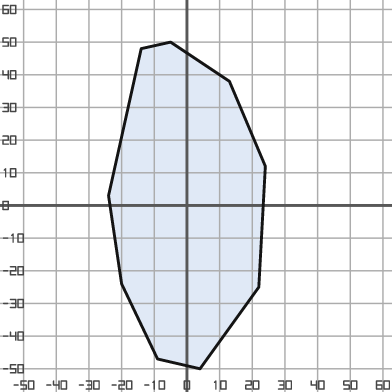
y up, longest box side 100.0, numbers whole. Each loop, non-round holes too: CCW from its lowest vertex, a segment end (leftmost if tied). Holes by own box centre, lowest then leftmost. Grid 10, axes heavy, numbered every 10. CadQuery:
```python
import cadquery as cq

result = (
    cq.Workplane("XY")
    .moveTo(4.0, -50.0)
    .lineTo(22.0, -25.0)
    .lineTo(24.0, 12.0)
    .lineTo(13.0, 38.0)
    .lineTo(-5.0, 50.0)
    .lineTo(-14.0, 48.0)
    .lineTo(-24.0, 3.0)
    .lineTo(-20.0, -24.0)
    .lineTo(-9.0, -47.0)
    .close()
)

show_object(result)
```